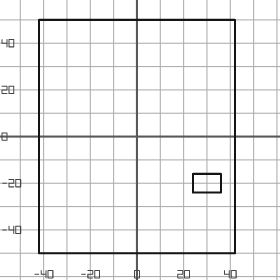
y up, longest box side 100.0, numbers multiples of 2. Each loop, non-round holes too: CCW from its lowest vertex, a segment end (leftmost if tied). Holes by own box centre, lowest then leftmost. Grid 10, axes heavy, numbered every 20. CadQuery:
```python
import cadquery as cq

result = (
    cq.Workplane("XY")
    .moveTo(-42.0, -50.0)
    .lineTo(42.0, -50.0)
    .lineTo(42.0, 50.0)
    .lineTo(-42.0, 50.0)
    .close()
    .moveTo(24.0, -24.0)
    .lineTo(36.0, -24.0)
    .lineTo(36.0, -16.0)
    .lineTo(24.0, -16.0)
    .close()
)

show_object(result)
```